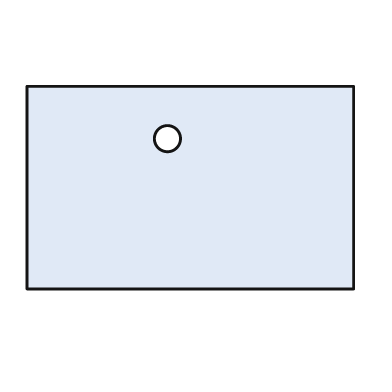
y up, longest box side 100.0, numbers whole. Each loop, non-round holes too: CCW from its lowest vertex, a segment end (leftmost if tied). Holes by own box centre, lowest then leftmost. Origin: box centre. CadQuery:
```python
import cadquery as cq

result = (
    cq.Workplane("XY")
    .moveTo(-50.0, -31.0)
    .lineTo(50.0, -31.0)
    .lineTo(50.0, 31.0)
    .lineTo(-50.0, 31.0)
    .close()
    .moveTo(-7.0, 15.0)
    .circle(4.0)
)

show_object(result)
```